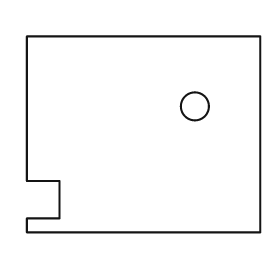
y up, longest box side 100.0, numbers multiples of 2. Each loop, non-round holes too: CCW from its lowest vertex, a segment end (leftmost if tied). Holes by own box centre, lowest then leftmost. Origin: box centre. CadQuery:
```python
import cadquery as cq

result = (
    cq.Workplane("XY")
    .moveTo(-50.0, -42.0)
    .lineTo(50.0, -42.0)
    .lineTo(50.0, 42.0)
    .lineTo(-50.0, 42.0)
    .lineTo(-50.0, -20.0)
    .lineTo(-36.0, -20.0)
    .lineTo(-36.0, -36.0)
    .lineTo(-50.0, -36.0)
    .close()
    .moveTo(22.0, 12.0)
    .circle(6.0)
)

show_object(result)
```